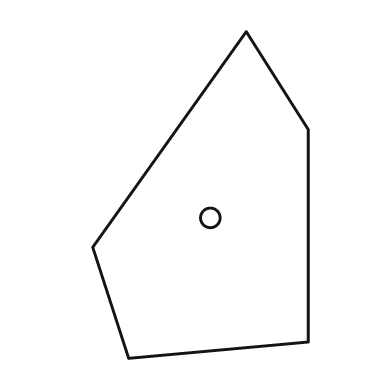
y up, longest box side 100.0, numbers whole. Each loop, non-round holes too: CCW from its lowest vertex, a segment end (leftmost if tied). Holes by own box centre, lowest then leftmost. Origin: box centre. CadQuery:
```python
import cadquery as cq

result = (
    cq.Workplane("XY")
    .moveTo(-22.0, -50.0)
    .lineTo(33.0, -45.0)
    .lineTo(33.0, 20.0)
    .lineTo(14.0, 50.0)
    .lineTo(-33.0, -16.0)
    .close()
    .moveTo(3.0, -7.0)
    .circle(3.0)
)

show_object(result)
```